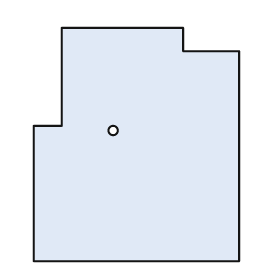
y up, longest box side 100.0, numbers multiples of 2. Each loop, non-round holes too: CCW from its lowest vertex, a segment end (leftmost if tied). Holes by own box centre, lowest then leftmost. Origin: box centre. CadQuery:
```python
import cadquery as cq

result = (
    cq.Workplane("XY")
    .moveTo(-44.0, -50.0)
    .lineTo(44.0, -50.0)
    .lineTo(44.0, 40.0)
    .lineTo(20.0, 40.0)
    .lineTo(20.0, 50.0)
    .lineTo(-32.0, 50.0)
    .lineTo(-32.0, 8.0)
    .lineTo(-44.0, 8.0)
    .close()
    .moveTo(-10.0, 6.0)
    .circle(2.0)
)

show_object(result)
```